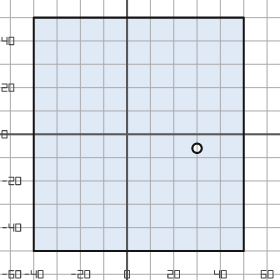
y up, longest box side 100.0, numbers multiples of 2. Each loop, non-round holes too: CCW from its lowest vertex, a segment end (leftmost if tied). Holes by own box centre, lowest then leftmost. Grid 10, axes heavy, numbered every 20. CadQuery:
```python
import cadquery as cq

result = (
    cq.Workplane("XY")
    .moveTo(-40.0, -50.0)
    .lineTo(50.0, -50.0)
    .lineTo(50.0, 50.0)
    .lineTo(-40.0, 50.0)
    .close()
    .moveTo(30.0, -6.0)
    .circle(2.0)
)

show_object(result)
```